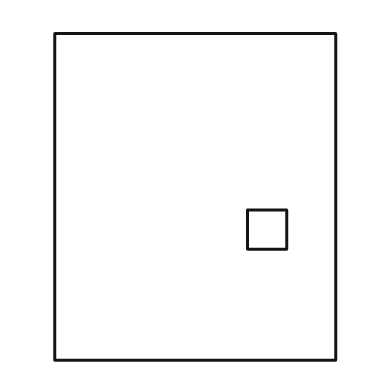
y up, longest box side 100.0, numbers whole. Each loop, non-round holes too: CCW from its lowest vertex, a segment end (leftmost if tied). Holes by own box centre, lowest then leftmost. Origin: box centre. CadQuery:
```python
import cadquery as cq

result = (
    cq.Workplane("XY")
    .moveTo(-43.0, -50.0)
    .lineTo(43.0, -50.0)
    .lineTo(43.0, 50.0)
    .lineTo(-43.0, 50.0)
    .close()
    .moveTo(16.0, -16.0)
    .lineTo(28.0, -16.0)
    .lineTo(28.0, -4.0)
    .lineTo(16.0, -4.0)
    .close()
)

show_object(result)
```